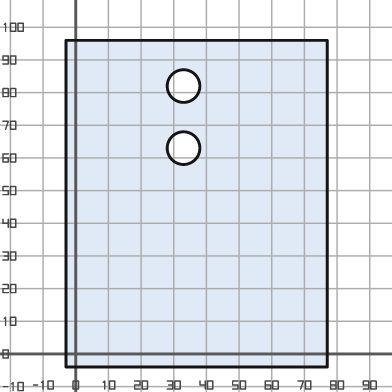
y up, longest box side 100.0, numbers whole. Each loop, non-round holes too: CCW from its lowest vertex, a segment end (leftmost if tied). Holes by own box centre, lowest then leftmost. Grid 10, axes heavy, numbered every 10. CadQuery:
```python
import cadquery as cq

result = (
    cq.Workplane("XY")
    .moveTo(-3.0, -4.0)
    .lineTo(77.0, -4.0)
    .lineTo(77.0, 96.0)
    .lineTo(-3.0, 96.0)
    .close()
    .moveTo(33.0, 63.0)
    .circle(5.0)
    .moveTo(33.0, 82.0)
    .circle(5.0)
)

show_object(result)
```